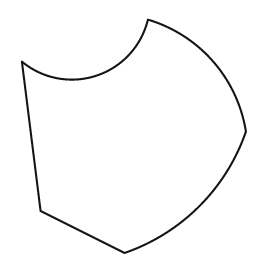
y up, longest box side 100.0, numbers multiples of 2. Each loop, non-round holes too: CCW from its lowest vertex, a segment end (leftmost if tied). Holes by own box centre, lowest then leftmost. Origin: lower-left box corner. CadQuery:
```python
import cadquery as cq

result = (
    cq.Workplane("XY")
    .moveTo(44.0, 0.0)
    .threePointArc((76.0, 20.0), (96.0, 52.0))
    .threePointArc((82.0, 82.0), (54.0, 100.0))
    .threePointArc((32.0, 76.0), (0.0, 82.0))
    .lineTo(8.0, 18.0)
    .close()
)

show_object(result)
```